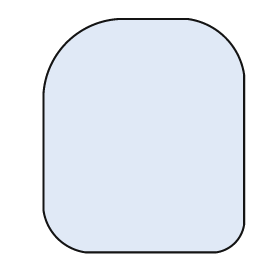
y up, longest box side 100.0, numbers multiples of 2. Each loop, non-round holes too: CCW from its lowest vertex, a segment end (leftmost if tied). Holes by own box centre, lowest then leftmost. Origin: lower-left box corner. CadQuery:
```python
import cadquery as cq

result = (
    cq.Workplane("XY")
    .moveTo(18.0, 0.0)
    .lineTo(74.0, 0.0)
    .threePointArc((82.0, 4.0), (86.0, 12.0))
    .lineTo(86.0, 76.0)
    .threePointArc((78.0, 92.0), (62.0, 100.0))
    .lineTo(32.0, 100.0)
    .threePointArc((10.0, 90.0), (0.0, 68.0))
    .lineTo(0.0, 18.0)
    .threePointArc((6.0, 6.0), (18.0, 0.0))
    .close()
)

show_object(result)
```